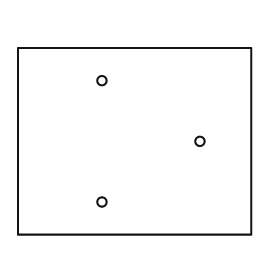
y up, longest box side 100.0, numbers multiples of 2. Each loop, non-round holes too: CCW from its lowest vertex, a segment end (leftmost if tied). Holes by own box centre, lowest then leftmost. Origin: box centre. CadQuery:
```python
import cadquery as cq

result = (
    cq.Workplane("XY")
    .moveTo(-50.0, -40.0)
    .lineTo(50.0, -40.0)
    .lineTo(50.0, 40.0)
    .lineTo(-50.0, 40.0)
    .close()
    .moveTo(-14.0, -26.0)
    .circle(2.0)
    .moveTo(28.0, 0.0)
    .circle(2.0)
    .moveTo(-14.0, 26.0)
    .circle(2.0)
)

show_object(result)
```